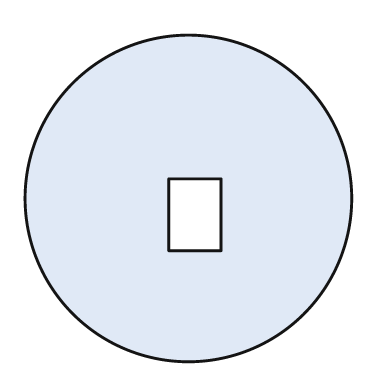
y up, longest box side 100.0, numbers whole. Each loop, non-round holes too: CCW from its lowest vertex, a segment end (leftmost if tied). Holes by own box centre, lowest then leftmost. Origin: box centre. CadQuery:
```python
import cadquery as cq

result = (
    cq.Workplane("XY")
    .moveTo(0.0, 0.0)
    .circle(50.0)
    .moveTo(-6.0, -16.0)
    .lineTo(10.0, -16.0)
    .lineTo(10.0, 6.0)
    .lineTo(-6.0, 6.0)
    .close()
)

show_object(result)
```